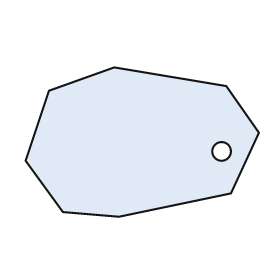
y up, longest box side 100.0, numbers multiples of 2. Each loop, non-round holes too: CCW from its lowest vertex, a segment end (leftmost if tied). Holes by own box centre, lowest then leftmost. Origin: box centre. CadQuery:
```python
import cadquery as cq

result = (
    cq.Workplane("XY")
    .moveTo(-10.0, -32.0)
    .lineTo(38.0, -22.0)
    .lineTo(50.0, 4.0)
    .lineTo(36.0, 24.0)
    .lineTo(-12.0, 32.0)
    .lineTo(-40.0, 22.0)
    .lineTo(-50.0, -8.0)
    .lineTo(-34.0, -30.0)
    .close()
    .moveTo(34.0, -4.0)
    .circle(4.0)
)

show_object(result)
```